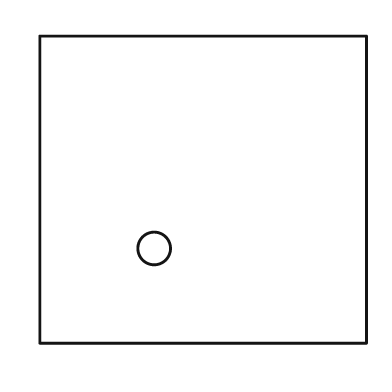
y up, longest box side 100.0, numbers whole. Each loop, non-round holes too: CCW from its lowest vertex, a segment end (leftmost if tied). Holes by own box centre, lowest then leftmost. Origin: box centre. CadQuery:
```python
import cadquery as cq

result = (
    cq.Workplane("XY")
    .moveTo(-50.0, -47.0)
    .lineTo(50.0, -47.0)
    .lineTo(50.0, 47.0)
    .lineTo(-50.0, 47.0)
    .close()
    .moveTo(-15.0, -18.0)
    .circle(5.0)
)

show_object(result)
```